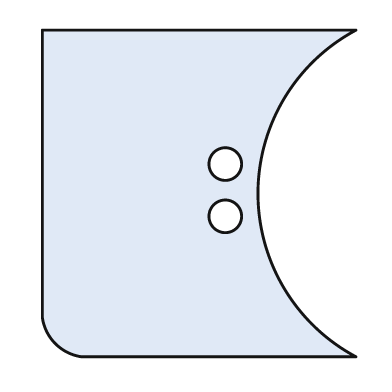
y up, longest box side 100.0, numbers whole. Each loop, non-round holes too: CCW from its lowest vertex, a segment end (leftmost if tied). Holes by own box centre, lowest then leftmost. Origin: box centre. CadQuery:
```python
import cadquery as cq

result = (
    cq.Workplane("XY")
    .moveTo(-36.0, -50.0)
    .lineTo(48.0, -50.0)
    .threePointArc((18.0, 0.0), (48.0, 50.0))
    .lineTo(-48.0, 50.0)
    .lineTo(-48.0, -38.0)
    .threePointArc((-44.0, -46.0), (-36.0, -50.0))
    .close()
    .moveTo(8.0, -7.0)
    .circle(5.0)
    .moveTo(8.0, 9.0)
    .circle(5.0)
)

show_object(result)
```